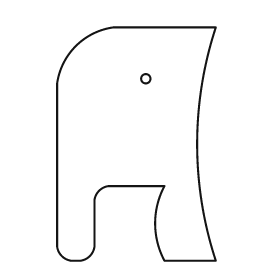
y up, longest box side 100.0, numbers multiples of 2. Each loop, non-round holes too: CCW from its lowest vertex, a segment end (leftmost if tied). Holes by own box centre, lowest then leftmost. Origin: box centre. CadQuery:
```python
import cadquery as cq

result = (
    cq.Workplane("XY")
    .moveTo(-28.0, -50.0)
    .lineTo(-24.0, -50.0)
    .threePointArc((-20.0, -48.0), (-18.0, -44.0))
    .lineTo(-18.0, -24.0)
    .threePointArc((-16.0, -20.0), (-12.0, -18.0))
    .lineTo(12.0, -18.0)
    .threePointArc((8.0, -34.0), (12.0, -50.0))
    .lineTo(34.0, -50.0)
    .threePointArc((26.0, 0.0), (34.0, 50.0))
    .lineTo(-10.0, 50.0)
    .threePointArc((-26.0, 42.0), (-34.0, 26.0))
    .lineTo(-34.0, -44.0)
    .threePointArc((-32.0, -48.0), (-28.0, -50.0))
    .close()
    .moveTo(4.0, 28.0)
    .circle(2.0)
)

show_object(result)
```